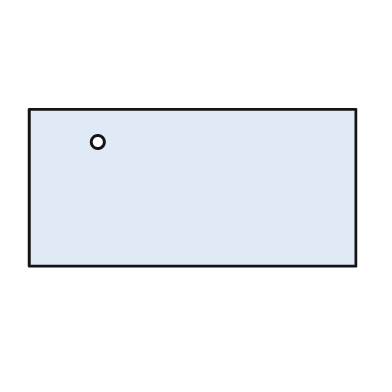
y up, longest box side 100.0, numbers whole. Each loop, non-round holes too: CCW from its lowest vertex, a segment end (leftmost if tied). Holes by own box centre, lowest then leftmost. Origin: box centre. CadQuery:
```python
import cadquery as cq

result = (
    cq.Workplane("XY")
    .moveTo(-50.0, -24.0)
    .lineTo(50.0, -24.0)
    .lineTo(50.0, 24.0)
    .lineTo(-50.0, 24.0)
    .close()
    .moveTo(-29.0, 14.0)
    .circle(2.0)
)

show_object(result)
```